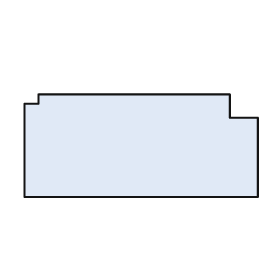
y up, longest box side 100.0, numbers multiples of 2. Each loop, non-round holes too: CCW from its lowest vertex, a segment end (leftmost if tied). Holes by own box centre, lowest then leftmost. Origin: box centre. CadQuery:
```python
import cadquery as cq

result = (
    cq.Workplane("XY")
    .moveTo(-50.0, -22.0)
    .lineTo(50.0, -22.0)
    .lineTo(50.0, 12.0)
    .lineTo(38.0, 12.0)
    .lineTo(38.0, 22.0)
    .lineTo(-44.0, 22.0)
    .lineTo(-44.0, 18.0)
    .lineTo(-50.0, 18.0)
    .close()
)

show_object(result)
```